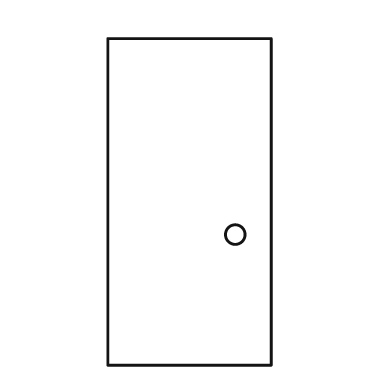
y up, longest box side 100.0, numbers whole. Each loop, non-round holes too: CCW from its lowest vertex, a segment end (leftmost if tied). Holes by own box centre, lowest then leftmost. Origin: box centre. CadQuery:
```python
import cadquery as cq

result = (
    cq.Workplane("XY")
    .moveTo(-25.0, -50.0)
    .lineTo(25.0, -50.0)
    .lineTo(25.0, 50.0)
    .lineTo(-25.0, 50.0)
    .close()
    .moveTo(14.0, -10.0)
    .circle(3.0)
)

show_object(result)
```